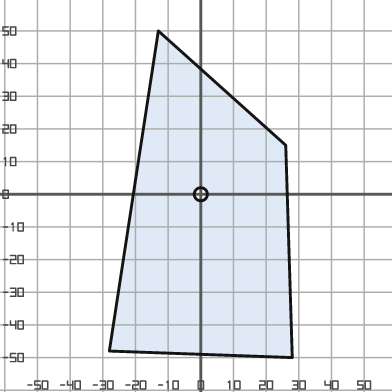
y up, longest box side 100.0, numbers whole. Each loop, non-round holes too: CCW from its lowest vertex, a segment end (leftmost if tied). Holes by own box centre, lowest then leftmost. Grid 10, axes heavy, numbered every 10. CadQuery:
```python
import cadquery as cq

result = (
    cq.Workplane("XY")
    .moveTo(28.0, -50.0)
    .lineTo(26.0, 15.0)
    .lineTo(-13.0, 50.0)
    .lineTo(-28.0, -48.0)
    .close()
    .moveTo(0.0, 0.0)
    .circle(2.0)
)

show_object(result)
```